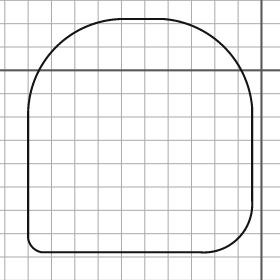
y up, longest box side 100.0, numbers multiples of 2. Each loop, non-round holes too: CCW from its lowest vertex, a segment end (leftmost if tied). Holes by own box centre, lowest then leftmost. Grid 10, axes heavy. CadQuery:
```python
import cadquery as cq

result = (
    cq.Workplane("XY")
    .moveTo(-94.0, -78.0)
    .lineTo(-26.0, -78.0)
    .threePointArc((-10.0, -72.0), (-4.0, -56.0))
    .lineTo(-4.0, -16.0)
    .threePointArc((-16.0, 10.0), (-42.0, 22.0))
    .lineTo(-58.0, 22.0)
    .threePointArc((-88.0, 10.0), (-100.0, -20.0))
    .lineTo(-100.0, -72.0)
    .threePointArc((-98.0, -76.0), (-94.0, -78.0))
    .close()
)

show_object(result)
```